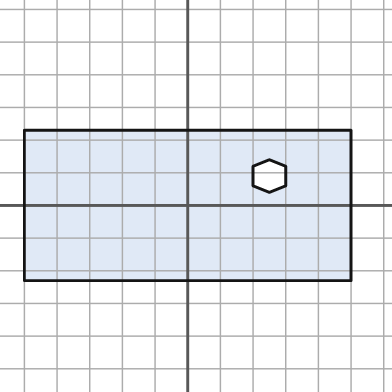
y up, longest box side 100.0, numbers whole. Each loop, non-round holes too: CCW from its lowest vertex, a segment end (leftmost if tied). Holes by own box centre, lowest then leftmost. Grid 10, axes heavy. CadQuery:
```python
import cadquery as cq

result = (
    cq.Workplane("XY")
    .moveTo(-50.0, -23.0)
    .lineTo(50.0, -23.0)
    .lineTo(50.0, 23.0)
    .lineTo(-50.0, 23.0)
    .close()
    .moveTo(25.0, 4.0)
    .lineTo(30.0, 6.0)
    .lineTo(30.0, 12.0)
    .lineTo(25.0, 14.0)
    .lineTo(20.0, 12.0)
    .lineTo(20.0, 6.0)
    .close()
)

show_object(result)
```